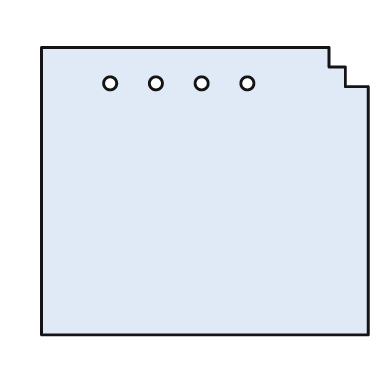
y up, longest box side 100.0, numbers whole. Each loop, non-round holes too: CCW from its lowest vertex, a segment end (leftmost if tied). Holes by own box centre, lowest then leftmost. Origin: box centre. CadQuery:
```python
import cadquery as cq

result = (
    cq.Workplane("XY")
    .moveTo(-50.0, -44.0)
    .lineTo(50.0, -44.0)
    .lineTo(50.0, 32.0)
    .lineTo(43.0, 32.0)
    .lineTo(43.0, 38.0)
    .lineTo(38.0, 38.0)
    .lineTo(38.0, 44.0)
    .lineTo(-50.0, 44.0)
    .close()
    .moveTo(-29.0, 33.0)
    .circle(2.0)
    .moveTo(-15.0, 33.0)
    .circle(2.0)
    .moveTo(-1.0, 33.0)
    .circle(2.0)
    .moveTo(13.0, 33.0)
    .circle(2.0)
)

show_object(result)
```